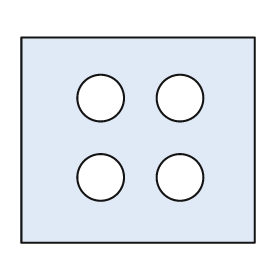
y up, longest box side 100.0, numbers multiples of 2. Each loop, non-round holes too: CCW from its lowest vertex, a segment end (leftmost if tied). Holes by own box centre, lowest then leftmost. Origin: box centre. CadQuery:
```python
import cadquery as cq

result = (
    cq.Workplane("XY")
    .moveTo(-50.0, -44.0)
    .lineTo(50.0, -44.0)
    .lineTo(50.0, 44.0)
    .lineTo(-50.0, 44.0)
    .close()
    .moveTo(-16.0, -16.0)
    .circle(10.0)
    .moveTo(18.0, -16.0)
    .circle(10.0)
    .moveTo(-16.0, 18.0)
    .circle(10.0)
    .moveTo(18.0, 18.0)
    .circle(10.0)
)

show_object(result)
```